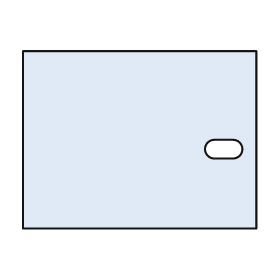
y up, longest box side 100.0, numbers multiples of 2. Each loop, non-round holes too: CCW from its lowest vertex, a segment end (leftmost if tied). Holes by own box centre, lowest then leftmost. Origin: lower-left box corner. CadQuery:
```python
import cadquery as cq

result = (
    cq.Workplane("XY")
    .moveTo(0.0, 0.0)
    .lineTo(100.0, 0.0)
    .lineTo(100.0, 76.0)
    .lineTo(0.0, 76.0)
    .close()
    .moveTo(82.0, 30.0)
    .lineTo(90.0, 30.0)
    .threePointArc((94.0, 34.0), (90.0, 38.0))
    .lineTo(82.0, 38.0)
    .threePointArc((78.0, 34.0), (82.0, 30.0))
    .close()
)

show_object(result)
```